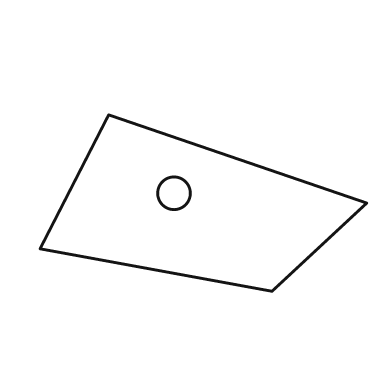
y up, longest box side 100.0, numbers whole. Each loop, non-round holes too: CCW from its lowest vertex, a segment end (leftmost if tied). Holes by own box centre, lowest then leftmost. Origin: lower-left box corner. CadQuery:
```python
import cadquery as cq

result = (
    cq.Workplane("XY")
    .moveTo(71.0, 0.0)
    .lineTo(100.0, 27.0)
    .lineTo(21.0, 54.0)
    .lineTo(0.0, 13.0)
    .close()
    .moveTo(41.0, 30.0)
    .circle(5.0)
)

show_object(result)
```